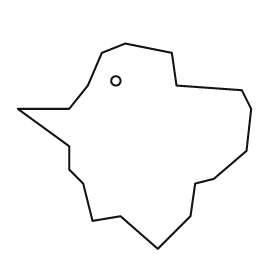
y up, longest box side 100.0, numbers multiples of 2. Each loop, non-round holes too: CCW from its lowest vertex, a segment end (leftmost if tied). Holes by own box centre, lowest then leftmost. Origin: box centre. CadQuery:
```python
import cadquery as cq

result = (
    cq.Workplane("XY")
    .moveTo(10.0, -44.0)
    .lineTo(24.0, -30.0)
    .lineTo(26.0, -16.0)
    .lineTo(34.0, -14.0)
    .lineTo(48.0, -2.0)
    .lineTo(50.0, 16.0)
    .lineTo(46.0, 24.0)
    .lineTo(18.0, 26.0)
    .lineTo(16.0, 40.0)
    .lineTo(-4.0, 44.0)
    .lineTo(-14.0, 40.0)
    .lineTo(-20.0, 26.0)
    .lineTo(-28.0, 16.0)
    .lineTo(-50.0, 16.0)
    .lineTo(-28.0, 0.0)
    .lineTo(-28.0, -10.0)
    .lineTo(-22.0, -16.0)
    .lineTo(-18.0, -32.0)
    .lineTo(-6.0, -30.0)
    .close()
    .moveTo(-8.0, 28.0)
    .circle(2.0)
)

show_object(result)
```